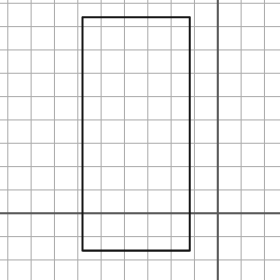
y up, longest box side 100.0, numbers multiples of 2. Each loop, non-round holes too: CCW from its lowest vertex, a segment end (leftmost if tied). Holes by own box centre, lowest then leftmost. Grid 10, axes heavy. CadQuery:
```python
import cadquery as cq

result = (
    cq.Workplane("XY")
    .moveTo(-58.0, -16.0)
    .lineTo(-12.0, -16.0)
    .lineTo(-12.0, 84.0)
    .lineTo(-58.0, 84.0)
    .close()
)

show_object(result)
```